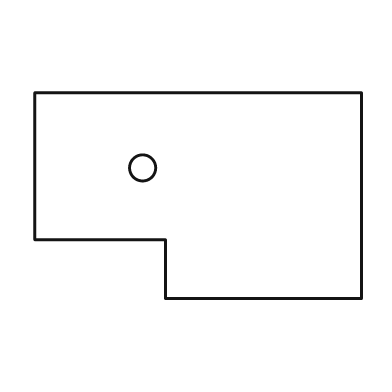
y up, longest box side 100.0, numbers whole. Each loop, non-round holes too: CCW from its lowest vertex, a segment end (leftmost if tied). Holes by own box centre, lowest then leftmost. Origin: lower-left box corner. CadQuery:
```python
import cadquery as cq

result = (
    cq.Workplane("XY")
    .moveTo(40.0, 0.0)
    .lineTo(100.0, 0.0)
    .lineTo(100.0, 63.0)
    .lineTo(0.0, 63.0)
    .lineTo(0.0, 18.0)
    .lineTo(40.0, 18.0)
    .close()
    .moveTo(33.0, 40.0)
    .circle(4.0)
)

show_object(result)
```